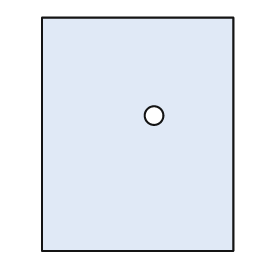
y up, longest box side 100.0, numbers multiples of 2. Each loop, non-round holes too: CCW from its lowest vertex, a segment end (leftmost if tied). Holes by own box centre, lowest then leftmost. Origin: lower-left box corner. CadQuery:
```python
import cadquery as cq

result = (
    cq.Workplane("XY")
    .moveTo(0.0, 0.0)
    .lineTo(82.0, 0.0)
    .lineTo(82.0, 100.0)
    .lineTo(0.0, 100.0)
    .close()
    .moveTo(48.0, 58.0)
    .circle(4.0)
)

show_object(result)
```